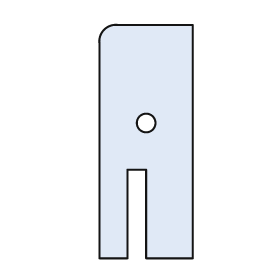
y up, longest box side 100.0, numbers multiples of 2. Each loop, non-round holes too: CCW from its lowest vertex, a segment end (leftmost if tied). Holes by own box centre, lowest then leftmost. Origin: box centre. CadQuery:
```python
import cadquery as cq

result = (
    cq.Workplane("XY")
    .moveTo(-20.0, -50.0)
    .lineTo(-8.0, -50.0)
    .lineTo(-8.0, -12.0)
    .lineTo(0.0, -12.0)
    .lineTo(0.0, -50.0)
    .lineTo(20.0, -50.0)
    .lineTo(20.0, 50.0)
    .lineTo(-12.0, 50.0)
    .threePointArc((-18.0, 48.0), (-20.0, 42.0))
    .close()
    .moveTo(0.0, 8.0)
    .circle(4.0)
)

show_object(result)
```